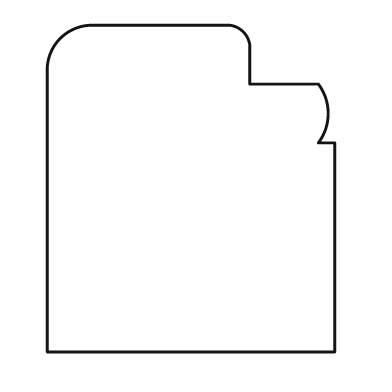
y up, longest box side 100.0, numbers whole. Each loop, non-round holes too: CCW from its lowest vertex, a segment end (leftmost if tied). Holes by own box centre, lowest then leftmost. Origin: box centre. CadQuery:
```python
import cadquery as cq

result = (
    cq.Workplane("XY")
    .moveTo(-44.0, -50.0)
    .lineTo(44.0, -50.0)
    .lineTo(44.0, 14.0)
    .lineTo(39.0, 14.0)
    .threePointArc((42.0, 23.0), (39.0, 32.0))
    .lineTo(18.0, 32.0)
    .lineTo(18.0, 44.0)
    .threePointArc((16.0, 48.0), (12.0, 50.0))
    .lineTo(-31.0, 50.0)
    .threePointArc((-40.0, 46.0), (-44.0, 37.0))
    .close()
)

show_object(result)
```